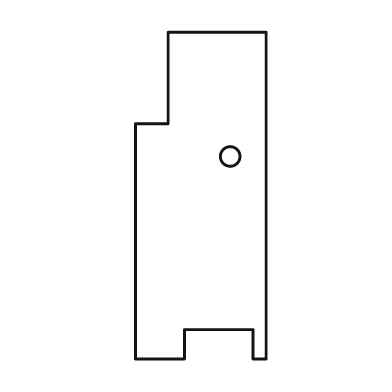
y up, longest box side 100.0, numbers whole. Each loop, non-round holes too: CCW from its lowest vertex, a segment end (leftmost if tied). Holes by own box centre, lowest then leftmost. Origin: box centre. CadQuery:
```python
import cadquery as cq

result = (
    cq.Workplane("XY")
    .moveTo(-20.0, -50.0)
    .lineTo(-5.0, -50.0)
    .lineTo(-5.0, -41.0)
    .lineTo(16.0, -41.0)
    .lineTo(16.0, -50.0)
    .lineTo(20.0, -50.0)
    .lineTo(20.0, 50.0)
    .lineTo(-10.0, 50.0)
    .lineTo(-10.0, 22.0)
    .lineTo(-20.0, 22.0)
    .close()
    .moveTo(9.0, 12.0)
    .circle(3.0)
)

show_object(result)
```